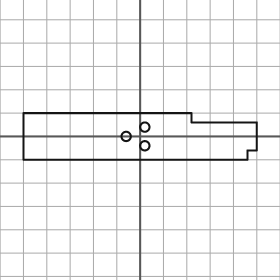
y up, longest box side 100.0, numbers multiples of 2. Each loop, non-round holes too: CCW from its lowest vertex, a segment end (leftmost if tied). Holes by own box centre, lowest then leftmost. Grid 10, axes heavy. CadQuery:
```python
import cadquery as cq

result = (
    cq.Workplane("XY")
    .moveTo(-50.0, -10.0)
    .lineTo(46.0, -10.0)
    .lineTo(46.0, -6.0)
    .lineTo(50.0, -6.0)
    .lineTo(50.0, 6.0)
    .lineTo(22.0, 6.0)
    .lineTo(22.0, 10.0)
    .lineTo(-50.0, 10.0)
    .close()
    .moveTo(2.0, -4.0)
    .circle(2.0)
    .moveTo(-6.0, 0.0)
    .circle(2.0)
    .moveTo(2.0, 4.0)
    .circle(2.0)
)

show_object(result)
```